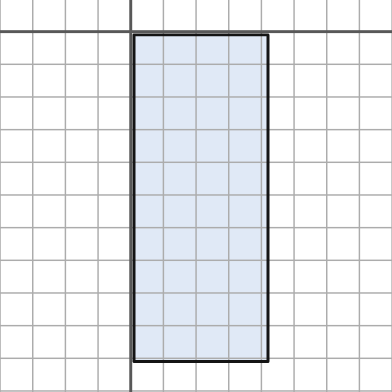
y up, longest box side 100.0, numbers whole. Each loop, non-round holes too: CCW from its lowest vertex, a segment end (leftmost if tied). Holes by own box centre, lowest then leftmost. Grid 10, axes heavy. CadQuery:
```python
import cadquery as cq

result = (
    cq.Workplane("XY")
    .moveTo(1.0, -101.0)
    .lineTo(42.0, -101.0)
    .lineTo(42.0, -1.0)
    .lineTo(1.0, -1.0)
    .close()
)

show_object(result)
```